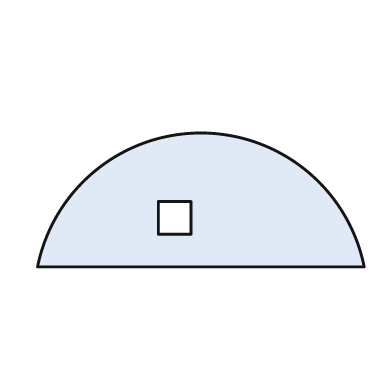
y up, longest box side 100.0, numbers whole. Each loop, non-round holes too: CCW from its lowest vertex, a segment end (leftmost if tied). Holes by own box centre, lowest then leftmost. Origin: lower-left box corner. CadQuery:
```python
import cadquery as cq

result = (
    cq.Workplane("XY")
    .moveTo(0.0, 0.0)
    .lineTo(100.0, 0.0)
    .threePointArc((50.0, 41.0), (0.0, 0.0))
    .close()
    .moveTo(37.0, 10.0)
    .lineTo(47.0, 10.0)
    .lineTo(47.0, 20.0)
    .lineTo(37.0, 20.0)
    .close()
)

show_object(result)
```